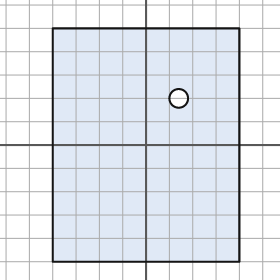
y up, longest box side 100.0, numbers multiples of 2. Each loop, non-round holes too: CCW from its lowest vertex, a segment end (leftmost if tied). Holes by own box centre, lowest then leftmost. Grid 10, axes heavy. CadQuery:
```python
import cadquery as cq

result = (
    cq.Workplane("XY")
    .moveTo(-40.0, -50.0)
    .lineTo(40.0, -50.0)
    .lineTo(40.0, 50.0)
    .lineTo(-40.0, 50.0)
    .close()
    .moveTo(14.0, 20.0)
    .circle(4.0)
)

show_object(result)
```